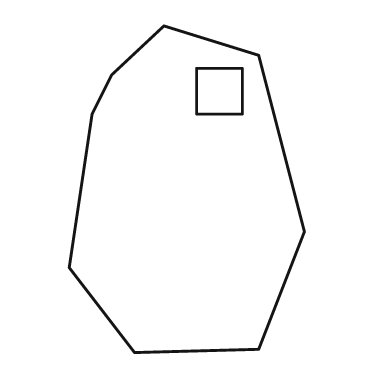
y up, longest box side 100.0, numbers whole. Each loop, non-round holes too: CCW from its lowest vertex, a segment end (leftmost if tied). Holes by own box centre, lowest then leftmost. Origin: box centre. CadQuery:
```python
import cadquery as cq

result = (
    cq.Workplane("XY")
    .moveTo(-16.0, -50.0)
    .lineTo(22.0, -49.0)
    .lineTo(36.0, -13.0)
    .lineTo(22.0, 41.0)
    .lineTo(-7.0, 50.0)
    .lineTo(-23.0, 35.0)
    .lineTo(-29.0, 23.0)
    .lineTo(-36.0, -24.0)
    .close()
    .moveTo(3.0, 23.0)
    .lineTo(17.0, 23.0)
    .lineTo(17.0, 37.0)
    .lineTo(3.0, 37.0)
    .close()
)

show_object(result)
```